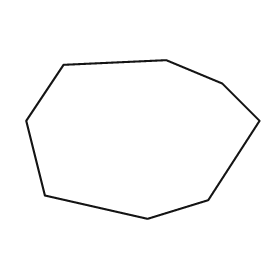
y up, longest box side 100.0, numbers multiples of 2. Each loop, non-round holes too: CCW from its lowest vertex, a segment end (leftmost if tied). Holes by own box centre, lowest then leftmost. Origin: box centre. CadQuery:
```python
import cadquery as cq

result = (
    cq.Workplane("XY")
    .moveTo(2.0, -34.0)
    .lineTo(28.0, -26.0)
    .lineTo(50.0, 8.0)
    .lineTo(34.0, 24.0)
    .lineTo(10.0, 34.0)
    .lineTo(-34.0, 32.0)
    .lineTo(-50.0, 8.0)
    .lineTo(-42.0, -24.0)
    .close()
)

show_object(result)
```